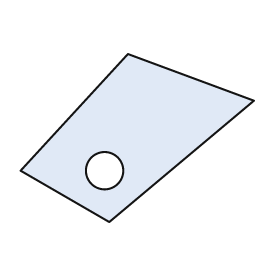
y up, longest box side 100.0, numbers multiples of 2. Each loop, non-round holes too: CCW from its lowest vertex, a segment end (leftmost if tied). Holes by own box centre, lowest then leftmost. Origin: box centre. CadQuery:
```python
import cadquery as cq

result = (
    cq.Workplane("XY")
    .moveTo(-12.0, -36.0)
    .lineTo(50.0, 16.0)
    .lineTo(-4.0, 36.0)
    .lineTo(-50.0, -14.0)
    .close()
    .moveTo(-14.0, -14.0)
    .circle(8.0)
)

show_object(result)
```